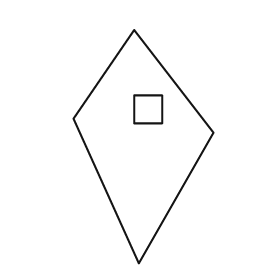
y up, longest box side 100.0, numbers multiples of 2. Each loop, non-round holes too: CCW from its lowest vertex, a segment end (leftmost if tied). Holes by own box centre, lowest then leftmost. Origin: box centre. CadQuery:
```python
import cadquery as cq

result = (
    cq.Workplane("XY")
    .moveTo(-2.0, -50.0)
    .lineTo(30.0, 6.0)
    .lineTo(-4.0, 50.0)
    .lineTo(-30.0, 12.0)
    .close()
    .moveTo(-4.0, 10.0)
    .lineTo(8.0, 10.0)
    .lineTo(8.0, 22.0)
    .lineTo(-4.0, 22.0)
    .close()
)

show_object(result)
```